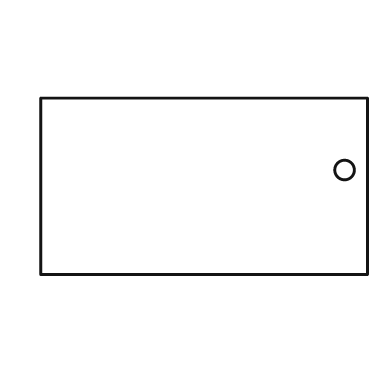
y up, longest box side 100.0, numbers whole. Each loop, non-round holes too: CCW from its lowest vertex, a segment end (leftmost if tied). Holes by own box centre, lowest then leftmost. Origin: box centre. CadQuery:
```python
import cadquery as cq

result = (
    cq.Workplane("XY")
    .moveTo(-50.0, -27.0)
    .lineTo(50.0, -27.0)
    .lineTo(50.0, 27.0)
    .lineTo(-50.0, 27.0)
    .close()
    .moveTo(43.0, 5.0)
    .circle(3.0)
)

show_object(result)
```